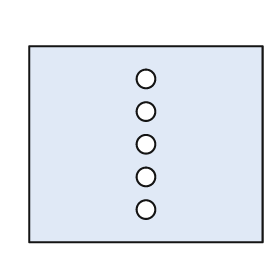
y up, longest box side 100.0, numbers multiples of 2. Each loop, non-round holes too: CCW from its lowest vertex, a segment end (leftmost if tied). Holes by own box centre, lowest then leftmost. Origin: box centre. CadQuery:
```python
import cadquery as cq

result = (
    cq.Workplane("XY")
    .moveTo(-50.0, -42.0)
    .lineTo(50.0, -42.0)
    .lineTo(50.0, 42.0)
    .lineTo(-50.0, 42.0)
    .close()
    .moveTo(0.0, -28.0)
    .circle(4.0)
    .moveTo(0.0, -14.0)
    .circle(4.0)
    .moveTo(0.0, 0.0)
    .circle(4.0)
    .moveTo(0.0, 14.0)
    .circle(4.0)
    .moveTo(0.0, 28.0)
    .circle(4.0)
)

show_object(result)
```